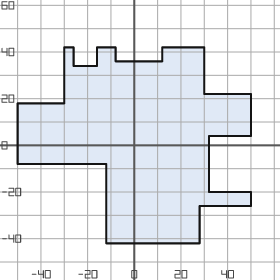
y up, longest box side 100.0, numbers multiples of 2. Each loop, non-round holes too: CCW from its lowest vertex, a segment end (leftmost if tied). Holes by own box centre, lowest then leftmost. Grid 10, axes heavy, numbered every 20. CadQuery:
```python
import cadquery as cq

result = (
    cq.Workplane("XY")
    .moveTo(-12.0, -42.0)
    .lineTo(28.0, -42.0)
    .lineTo(28.0, -26.0)
    .lineTo(50.0, -26.0)
    .lineTo(50.0, -20.0)
    .lineTo(32.0, -20.0)
    .lineTo(32.0, 4.0)
    .lineTo(50.0, 4.0)
    .lineTo(50.0, 22.0)
    .lineTo(30.0, 22.0)
    .lineTo(30.0, 42.0)
    .lineTo(12.0, 42.0)
    .lineTo(12.0, 36.0)
    .lineTo(-8.0, 36.0)
    .lineTo(-8.0, 42.0)
    .lineTo(-16.0, 42.0)
    .lineTo(-16.0, 34.0)
    .lineTo(-26.0, 34.0)
    .lineTo(-26.0, 42.0)
    .lineTo(-30.0, 42.0)
    .lineTo(-30.0, 18.0)
    .lineTo(-50.0, 18.0)
    .lineTo(-50.0, -8.0)
    .lineTo(-12.0, -8.0)
    .close()
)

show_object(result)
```